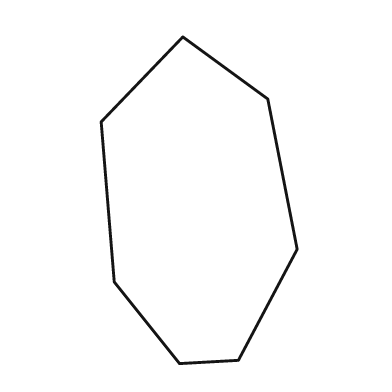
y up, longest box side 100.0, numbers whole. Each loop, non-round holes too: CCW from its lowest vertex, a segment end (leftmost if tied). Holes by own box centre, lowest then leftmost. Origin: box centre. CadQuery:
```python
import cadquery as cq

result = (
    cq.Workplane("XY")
    .moveTo(-6.0, -50.0)
    .lineTo(12.0, -49.0)
    .lineTo(30.0, -15.0)
    .lineTo(21.0, 31.0)
    .lineTo(-5.0, 50.0)
    .lineTo(-30.0, 24.0)
    .lineTo(-26.0, -25.0)
    .close()
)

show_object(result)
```